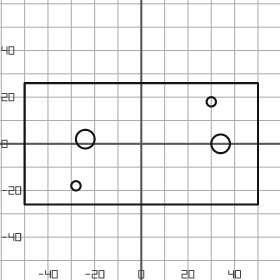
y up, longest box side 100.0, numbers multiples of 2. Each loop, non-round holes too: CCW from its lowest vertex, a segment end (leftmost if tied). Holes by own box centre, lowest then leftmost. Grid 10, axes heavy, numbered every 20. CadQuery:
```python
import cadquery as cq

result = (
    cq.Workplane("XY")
    .moveTo(-50.0, -26.0)
    .lineTo(50.0, -26.0)
    .lineTo(50.0, 26.0)
    .lineTo(-50.0, 26.0)
    .close()
    .moveTo(-28.0, -18.0)
    .circle(2.0)
    .moveTo(34.0, 0.0)
    .circle(4.0)
    .moveTo(-24.0, 2.0)
    .circle(4.0)
    .moveTo(30.0, 18.0)
    .circle(2.0)
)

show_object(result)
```